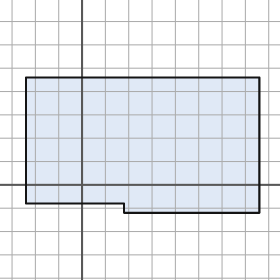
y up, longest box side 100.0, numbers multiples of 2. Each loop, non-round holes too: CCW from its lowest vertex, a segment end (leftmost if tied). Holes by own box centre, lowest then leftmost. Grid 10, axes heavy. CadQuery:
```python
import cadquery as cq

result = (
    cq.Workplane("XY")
    .moveTo(18.0, -12.0)
    .lineTo(76.0, -12.0)
    .lineTo(76.0, 46.0)
    .lineTo(-24.0, 46.0)
    .lineTo(-24.0, -8.0)
    .lineTo(18.0, -8.0)
    .close()
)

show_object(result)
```